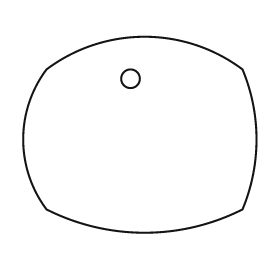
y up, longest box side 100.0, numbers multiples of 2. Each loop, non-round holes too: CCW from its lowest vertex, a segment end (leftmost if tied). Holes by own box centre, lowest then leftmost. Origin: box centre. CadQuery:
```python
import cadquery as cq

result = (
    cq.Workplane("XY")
    .moveTo(-40.0, -32.0)
    .threePointArc((2.0, -42.0), (44.0, -32.0))
    .threePointArc((50.0, -2.0), (44.0, 28.0))
    .threePointArc((2.0, 42.0), (-40.0, 28.0))
    .threePointArc((-50.0, -2.0), (-40.0, -32.0))
    .close()
    .moveTo(-4.0, 24.0)
    .circle(4.0)
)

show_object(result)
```